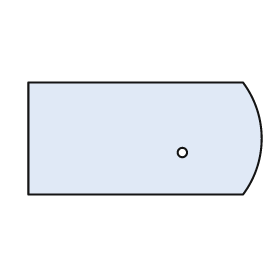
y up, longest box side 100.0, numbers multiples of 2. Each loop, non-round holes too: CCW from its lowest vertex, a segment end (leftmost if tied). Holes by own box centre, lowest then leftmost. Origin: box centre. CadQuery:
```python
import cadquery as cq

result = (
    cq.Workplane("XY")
    .moveTo(-50.0, -24.0)
    .lineTo(42.0, -24.0)
    .threePointArc((50.0, 0.0), (42.0, 24.0))
    .lineTo(-50.0, 24.0)
    .close()
    .moveTo(16.0, -6.0)
    .circle(2.0)
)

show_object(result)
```